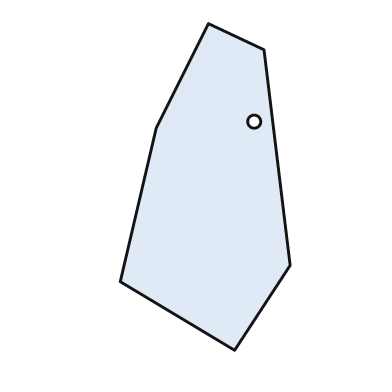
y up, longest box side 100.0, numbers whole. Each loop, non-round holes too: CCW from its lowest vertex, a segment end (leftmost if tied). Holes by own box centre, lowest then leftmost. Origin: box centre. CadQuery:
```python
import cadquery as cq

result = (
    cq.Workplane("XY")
    .moveTo(9.0, -50.0)
    .lineTo(26.0, -24.0)
    .lineTo(18.0, 42.0)
    .lineTo(1.0, 50.0)
    .lineTo(-15.0, 18.0)
    .lineTo(-26.0, -29.0)
    .close()
    .moveTo(15.0, 20.0)
    .circle(2.0)
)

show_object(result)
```